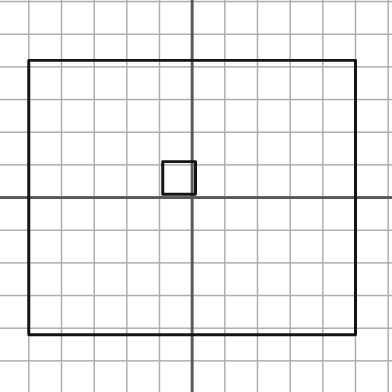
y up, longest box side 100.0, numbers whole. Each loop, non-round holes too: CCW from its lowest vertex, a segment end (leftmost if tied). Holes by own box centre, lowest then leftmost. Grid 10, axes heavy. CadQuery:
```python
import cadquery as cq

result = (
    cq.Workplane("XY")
    .moveTo(-50.0, -42.0)
    .lineTo(50.0, -42.0)
    .lineTo(50.0, 42.0)
    .lineTo(-50.0, 42.0)
    .close()
    .moveTo(-9.0, 1.0)
    .lineTo(1.0, 1.0)
    .lineTo(1.0, 11.0)
    .lineTo(-9.0, 11.0)
    .close()
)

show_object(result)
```